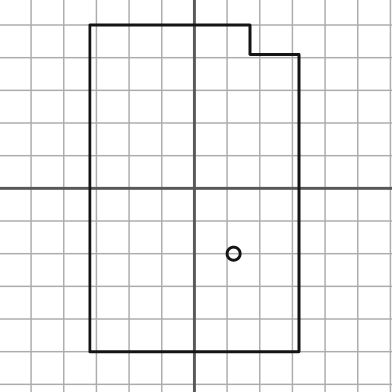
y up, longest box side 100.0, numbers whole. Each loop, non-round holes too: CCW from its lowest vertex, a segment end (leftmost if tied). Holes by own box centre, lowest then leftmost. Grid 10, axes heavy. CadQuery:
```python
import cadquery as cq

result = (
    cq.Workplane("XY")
    .moveTo(-32.0, -50.0)
    .lineTo(32.0, -50.0)
    .lineTo(32.0, 41.0)
    .lineTo(17.0, 41.0)
    .lineTo(17.0, 50.0)
    .lineTo(-32.0, 50.0)
    .close()
    .moveTo(12.0, -20.0)
    .circle(2.0)
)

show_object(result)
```